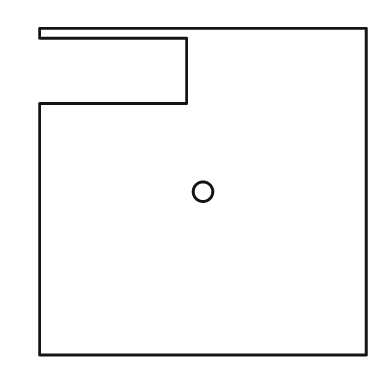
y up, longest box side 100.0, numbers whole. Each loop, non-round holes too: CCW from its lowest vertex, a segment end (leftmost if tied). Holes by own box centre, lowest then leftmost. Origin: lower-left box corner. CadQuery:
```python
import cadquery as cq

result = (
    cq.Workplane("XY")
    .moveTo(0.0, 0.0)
    .lineTo(100.0, 0.0)
    .lineTo(100.0, 100.0)
    .lineTo(0.0, 100.0)
    .lineTo(0.0, 97.0)
    .lineTo(45.0, 97.0)
    .lineTo(45.0, 77.0)
    .lineTo(0.0, 77.0)
    .close()
    .moveTo(50.0, 50.0)
    .circle(3.0)
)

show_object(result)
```